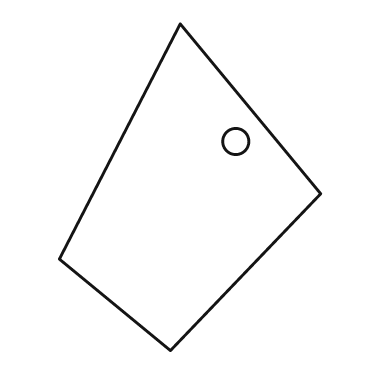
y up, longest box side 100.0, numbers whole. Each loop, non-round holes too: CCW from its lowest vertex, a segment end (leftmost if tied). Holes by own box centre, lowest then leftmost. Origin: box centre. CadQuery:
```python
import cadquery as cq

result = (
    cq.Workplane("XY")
    .moveTo(-6.0, -50.0)
    .lineTo(40.0, -2.0)
    .lineTo(-3.0, 50.0)
    .lineTo(-40.0, -22.0)
    .close()
    .moveTo(14.0, 14.0)
    .circle(4.0)
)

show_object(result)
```